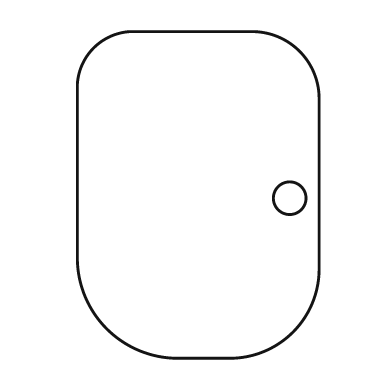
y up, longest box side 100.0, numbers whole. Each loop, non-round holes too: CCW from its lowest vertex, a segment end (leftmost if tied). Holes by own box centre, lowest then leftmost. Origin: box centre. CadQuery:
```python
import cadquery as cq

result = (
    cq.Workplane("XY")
    .moveTo(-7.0, -50.0)
    .lineTo(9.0, -50.0)
    .threePointArc((29.0, -42.0), (37.0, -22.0))
    .lineTo(37.0, 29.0)
    .threePointArc((31.0, 44.0), (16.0, 50.0))
    .lineTo(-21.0, 50.0)
    .threePointArc((-32.0, 45.0), (-37.0, 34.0))
    .lineTo(-37.0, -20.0)
    .threePointArc((-28.0, -41.0), (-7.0, -50.0))
    .close()
    .moveTo(28.0, -1.0)
    .circle(5.0)
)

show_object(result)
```